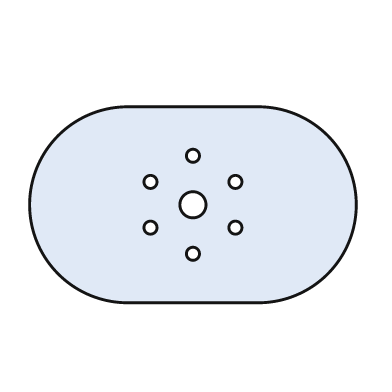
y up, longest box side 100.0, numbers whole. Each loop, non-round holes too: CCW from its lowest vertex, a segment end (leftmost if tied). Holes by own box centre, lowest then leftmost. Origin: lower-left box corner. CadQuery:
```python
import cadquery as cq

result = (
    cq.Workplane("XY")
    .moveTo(30.0, 0.0)
    .lineTo(70.0, 0.0)
    .threePointArc((100.0, 30.0), (70.0, 60.0))
    .lineTo(30.0, 60.0)
    .threePointArc((0.0, 30.0), (30.0, 0.0))
    .close()
    .moveTo(50.0, 15.0)
    .circle(2.0)
    .moveTo(37.0, 23.0)
    .circle(2.0)
    .moveTo(63.0, 23.0)
    .circle(2.0)
    .moveTo(50.0, 30.0)
    .circle(4.0)
    .moveTo(37.0, 37.0)
    .circle(2.0)
    .moveTo(63.0, 37.0)
    .circle(2.0)
    .moveTo(50.0, 45.0)
    .circle(2.0)
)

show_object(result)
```